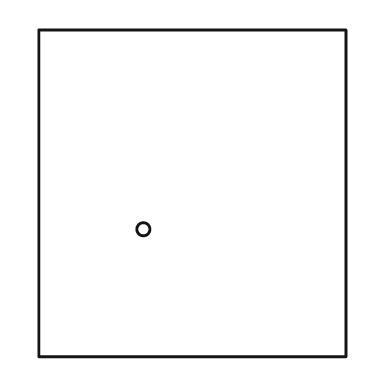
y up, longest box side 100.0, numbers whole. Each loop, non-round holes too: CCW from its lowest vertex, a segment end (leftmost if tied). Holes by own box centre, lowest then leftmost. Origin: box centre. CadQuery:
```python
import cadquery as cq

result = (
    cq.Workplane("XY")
    .moveTo(-47.0, -50.0)
    .lineTo(47.0, -50.0)
    .lineTo(47.0, 50.0)
    .lineTo(-47.0, 50.0)
    .close()
    .moveTo(-15.0, -11.0)
    .circle(2.0)
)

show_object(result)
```